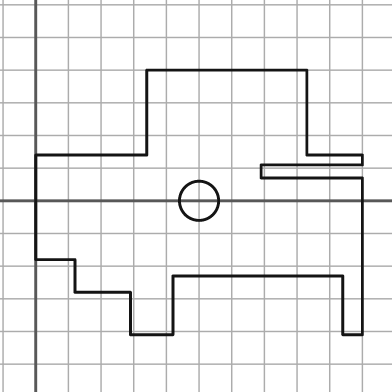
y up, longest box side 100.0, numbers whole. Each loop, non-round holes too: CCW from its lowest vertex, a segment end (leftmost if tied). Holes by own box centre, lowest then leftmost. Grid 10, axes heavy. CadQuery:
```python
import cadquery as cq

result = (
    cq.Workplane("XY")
    .moveTo(29.0, -41.0)
    .lineTo(42.0, -41.0)
    .lineTo(42.0, -23.0)
    .lineTo(94.0, -23.0)
    .lineTo(94.0, -41.0)
    .lineTo(100.0, -41.0)
    .lineTo(100.0, 7.0)
    .lineTo(69.0, 7.0)
    .lineTo(69.0, 11.0)
    .lineTo(100.0, 11.0)
    .lineTo(100.0, 14.0)
    .lineTo(83.0, 14.0)
    .lineTo(83.0, 40.0)
    .lineTo(34.0, 40.0)
    .lineTo(34.0, 14.0)
    .lineTo(0.0, 14.0)
    .lineTo(0.0, -18.0)
    .lineTo(12.0, -18.0)
    .lineTo(12.0, -28.0)
    .lineTo(29.0, -28.0)
    .close()
    .moveTo(50.0, 0.0)
    .circle(6.0)
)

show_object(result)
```